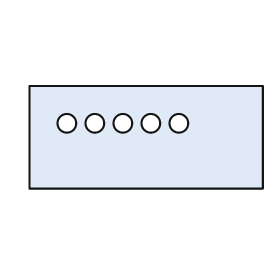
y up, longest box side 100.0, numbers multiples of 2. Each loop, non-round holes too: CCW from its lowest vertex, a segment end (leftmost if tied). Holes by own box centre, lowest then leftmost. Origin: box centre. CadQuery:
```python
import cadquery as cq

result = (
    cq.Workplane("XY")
    .moveTo(-50.0, -22.0)
    .lineTo(50.0, -22.0)
    .lineTo(50.0, 22.0)
    .lineTo(-50.0, 22.0)
    .close()
    .moveTo(-34.0, 6.0)
    .circle(4.0)
    .moveTo(-22.0, 6.0)
    .circle(4.0)
    .moveTo(-10.0, 6.0)
    .circle(4.0)
    .moveTo(2.0, 6.0)
    .circle(4.0)
    .moveTo(14.0, 6.0)
    .circle(4.0)
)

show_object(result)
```